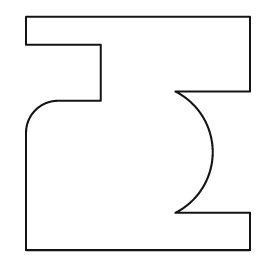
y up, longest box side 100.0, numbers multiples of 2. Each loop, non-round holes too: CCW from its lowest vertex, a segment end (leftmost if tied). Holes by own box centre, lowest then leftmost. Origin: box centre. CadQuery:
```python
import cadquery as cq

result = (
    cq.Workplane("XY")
    .moveTo(-48.0, -50.0)
    .lineTo(48.0, -50.0)
    .lineTo(48.0, -34.0)
    .lineTo(16.0, -34.0)
    .threePointArc((32.0, -8.0), (16.0, 18.0))
    .lineTo(48.0, 18.0)
    .lineTo(48.0, 50.0)
    .lineTo(-48.0, 50.0)
    .lineTo(-48.0, 38.0)
    .lineTo(-16.0, 38.0)
    .lineTo(-16.0, 14.0)
    .lineTo(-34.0, 14.0)
    .threePointArc((-44.0, 10.0), (-48.0, 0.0))
    .close()
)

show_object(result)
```